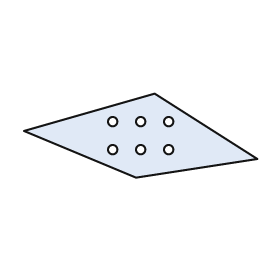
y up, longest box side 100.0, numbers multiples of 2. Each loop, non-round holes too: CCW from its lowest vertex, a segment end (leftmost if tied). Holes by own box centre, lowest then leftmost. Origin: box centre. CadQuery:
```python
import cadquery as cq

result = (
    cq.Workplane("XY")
    .moveTo(-2.0, -18.0)
    .lineTo(50.0, -10.0)
    .lineTo(6.0, 18.0)
    .lineTo(-50.0, 2.0)
    .close()
    .moveTo(-12.0, -6.0)
    .circle(2.0)
    .moveTo(0.0, -6.0)
    .circle(2.0)
    .moveTo(12.0, -6.0)
    .circle(2.0)
    .moveTo(-12.0, 6.0)
    .circle(2.0)
    .moveTo(0.0, 6.0)
    .circle(2.0)
    .moveTo(12.0, 6.0)
    .circle(2.0)
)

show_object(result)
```